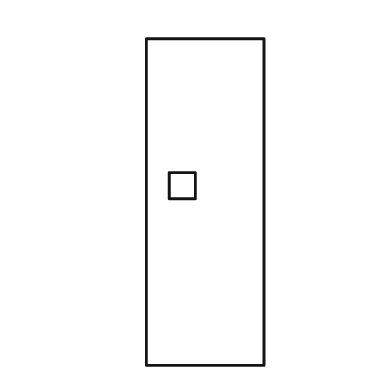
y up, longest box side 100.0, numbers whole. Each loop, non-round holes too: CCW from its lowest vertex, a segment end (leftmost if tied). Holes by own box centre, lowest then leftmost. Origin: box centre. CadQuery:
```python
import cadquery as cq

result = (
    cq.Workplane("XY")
    .moveTo(-18.0, -50.0)
    .lineTo(18.0, -50.0)
    .lineTo(18.0, 50.0)
    .lineTo(-18.0, 50.0)
    .close()
    .moveTo(-11.0, 1.0)
    .lineTo(-3.0, 1.0)
    .lineTo(-3.0, 9.0)
    .lineTo(-11.0, 9.0)
    .close()
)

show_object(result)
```